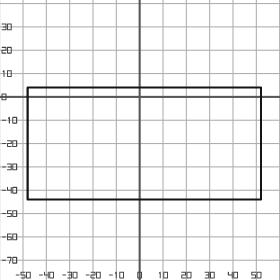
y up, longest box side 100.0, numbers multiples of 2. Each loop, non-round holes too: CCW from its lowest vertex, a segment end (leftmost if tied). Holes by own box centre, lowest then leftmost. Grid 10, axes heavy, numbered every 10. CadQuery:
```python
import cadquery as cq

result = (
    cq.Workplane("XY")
    .moveTo(-48.0, -44.0)
    .lineTo(52.0, -44.0)
    .lineTo(52.0, 4.0)
    .lineTo(-48.0, 4.0)
    .close()
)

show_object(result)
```